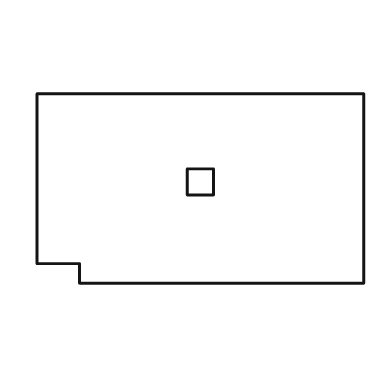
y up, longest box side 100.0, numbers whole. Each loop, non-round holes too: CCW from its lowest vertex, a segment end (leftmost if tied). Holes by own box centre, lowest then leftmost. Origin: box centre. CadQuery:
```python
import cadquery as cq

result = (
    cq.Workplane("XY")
    .moveTo(-37.0, -29.0)
    .lineTo(50.0, -29.0)
    .lineTo(50.0, 29.0)
    .lineTo(-50.0, 29.0)
    .lineTo(-50.0, -23.0)
    .lineTo(-37.0, -23.0)
    .close()
    .moveTo(-4.0, -2.0)
    .lineTo(4.0, -2.0)
    .lineTo(4.0, 6.0)
    .lineTo(-4.0, 6.0)
    .close()
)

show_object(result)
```